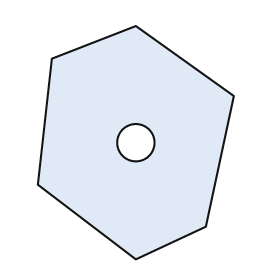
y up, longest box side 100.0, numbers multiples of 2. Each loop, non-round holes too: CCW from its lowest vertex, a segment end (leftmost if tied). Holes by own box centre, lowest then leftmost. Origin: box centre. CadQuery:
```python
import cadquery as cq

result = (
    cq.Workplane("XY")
    .moveTo(0.0, -50.0)
    .lineTo(30.0, -36.0)
    .lineTo(42.0, 20.0)
    .lineTo(0.0, 50.0)
    .lineTo(-36.0, 36.0)
    .lineTo(-42.0, -18.0)
    .close()
    .moveTo(0.0, 0.0)
    .circle(8.0)
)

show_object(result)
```